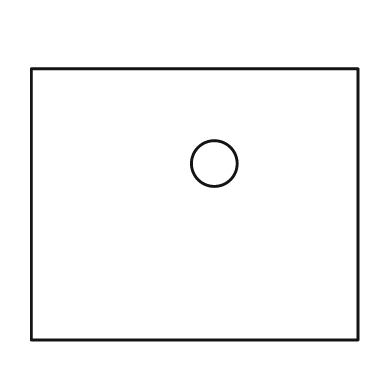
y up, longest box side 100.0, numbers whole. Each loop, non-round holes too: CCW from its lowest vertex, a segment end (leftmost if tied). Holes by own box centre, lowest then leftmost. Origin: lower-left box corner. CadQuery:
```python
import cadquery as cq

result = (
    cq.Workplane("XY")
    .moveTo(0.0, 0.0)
    .lineTo(100.0, 0.0)
    .lineTo(100.0, 83.0)
    .lineTo(0.0, 83.0)
    .close()
    .moveTo(56.0, 54.0)
    .circle(7.0)
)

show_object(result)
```